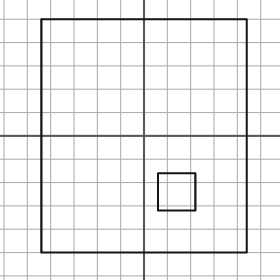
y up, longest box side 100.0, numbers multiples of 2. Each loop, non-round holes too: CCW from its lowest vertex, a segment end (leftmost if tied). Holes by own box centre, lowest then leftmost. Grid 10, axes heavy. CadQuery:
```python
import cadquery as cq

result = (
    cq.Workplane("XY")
    .moveTo(-44.0, -50.0)
    .lineTo(44.0, -50.0)
    .lineTo(44.0, 50.0)
    .lineTo(-44.0, 50.0)
    .close()
    .moveTo(6.0, -32.0)
    .lineTo(22.0, -32.0)
    .lineTo(22.0, -16.0)
    .lineTo(6.0, -16.0)
    .close()
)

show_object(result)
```